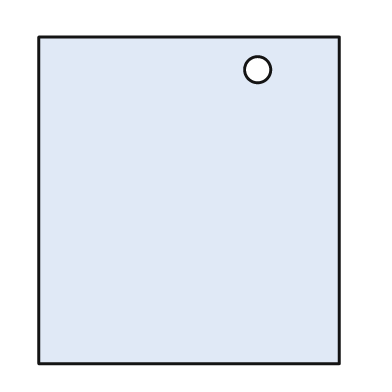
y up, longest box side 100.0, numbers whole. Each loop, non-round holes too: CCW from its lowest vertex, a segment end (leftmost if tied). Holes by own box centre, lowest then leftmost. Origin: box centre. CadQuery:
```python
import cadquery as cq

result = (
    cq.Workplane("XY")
    .moveTo(-46.0, -50.0)
    .lineTo(46.0, -50.0)
    .lineTo(46.0, 50.0)
    .lineTo(-46.0, 50.0)
    .close()
    .moveTo(21.0, 40.0)
    .circle(4.0)
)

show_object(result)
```